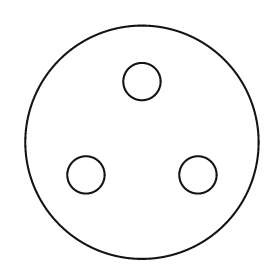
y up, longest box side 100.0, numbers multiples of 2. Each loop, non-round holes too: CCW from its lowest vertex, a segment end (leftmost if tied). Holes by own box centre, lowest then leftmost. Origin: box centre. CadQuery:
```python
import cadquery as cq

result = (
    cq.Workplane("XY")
    .moveTo(0.0, 0.0)
    .circle(50.0)
    .moveTo(-24.0, -14.0)
    .circle(8.0)
    .moveTo(24.0, -14.0)
    .circle(8.0)
    .moveTo(0.0, 26.0)
    .circle(8.0)
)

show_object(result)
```